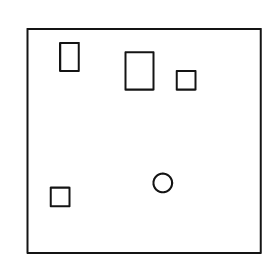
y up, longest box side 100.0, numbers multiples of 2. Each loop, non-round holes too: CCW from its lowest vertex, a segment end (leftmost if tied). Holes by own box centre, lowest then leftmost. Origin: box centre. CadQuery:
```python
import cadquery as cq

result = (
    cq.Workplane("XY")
    .moveTo(-50.0, -48.0)
    .lineTo(50.0, -48.0)
    .lineTo(50.0, 48.0)
    .lineTo(-50.0, 48.0)
    .close()
    .moveTo(-40.0, -28.0)
    .lineTo(-32.0, -28.0)
    .lineTo(-32.0, -20.0)
    .lineTo(-40.0, -20.0)
    .close()
    .moveTo(8.0, -18.0)
    .circle(4.0)
    .moveTo(14.0, 22.0)
    .lineTo(22.0, 22.0)
    .lineTo(22.0, 30.0)
    .lineTo(14.0, 30.0)
    .close()
    .moveTo(-8.0, 22.0)
    .lineTo(4.0, 22.0)
    .lineTo(4.0, 38.0)
    .lineTo(-8.0, 38.0)
    .close()
    .moveTo(-36.0, 30.0)
    .lineTo(-28.0, 30.0)
    .lineTo(-28.0, 42.0)
    .lineTo(-36.0, 42.0)
    .close()
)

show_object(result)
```